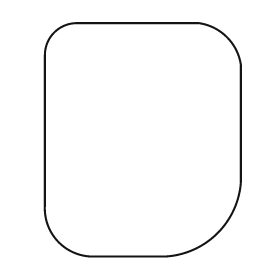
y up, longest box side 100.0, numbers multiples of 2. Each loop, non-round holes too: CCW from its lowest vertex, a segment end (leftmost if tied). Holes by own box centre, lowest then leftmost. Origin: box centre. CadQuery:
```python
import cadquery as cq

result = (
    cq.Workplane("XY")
    .moveTo(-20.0, -50.0)
    .lineTo(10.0, -50.0)
    .threePointArc((32.0, -40.0), (42.0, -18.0))
    .lineTo(42.0, 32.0)
    .threePointArc((36.0, 44.0), (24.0, 50.0))
    .lineTo(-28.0, 50.0)
    .threePointArc((-38.0, 46.0), (-42.0, 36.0))
    .lineTo(-42.0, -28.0)
    .threePointArc((-36.0, -44.0), (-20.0, -50.0))
    .close()
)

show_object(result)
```